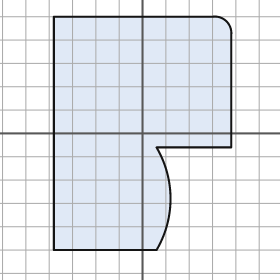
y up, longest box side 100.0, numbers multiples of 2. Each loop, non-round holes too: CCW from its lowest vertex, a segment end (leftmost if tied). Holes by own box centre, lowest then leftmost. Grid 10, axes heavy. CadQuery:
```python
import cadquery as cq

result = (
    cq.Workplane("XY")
    .moveTo(-38.0, -50.0)
    .lineTo(6.0, -50.0)
    .threePointArc((12.0, -28.0), (6.0, -6.0))
    .lineTo(38.0, -6.0)
    .lineTo(38.0, 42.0)
    .threePointArc((36.0, 48.0), (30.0, 50.0))
    .lineTo(-38.0, 50.0)
    .close()
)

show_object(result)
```